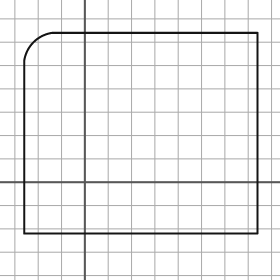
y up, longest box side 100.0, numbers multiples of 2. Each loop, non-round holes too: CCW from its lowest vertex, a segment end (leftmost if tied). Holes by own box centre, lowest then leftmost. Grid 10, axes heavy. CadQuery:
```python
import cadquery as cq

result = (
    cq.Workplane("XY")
    .moveTo(-26.0, -22.0)
    .lineTo(74.0, -22.0)
    .lineTo(74.0, 64.0)
    .lineTo(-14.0, 64.0)
    .threePointArc((-22.0, 60.0), (-26.0, 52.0))
    .close()
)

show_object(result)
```